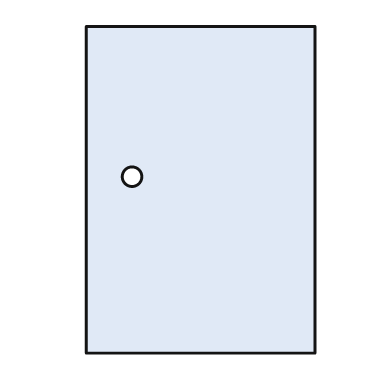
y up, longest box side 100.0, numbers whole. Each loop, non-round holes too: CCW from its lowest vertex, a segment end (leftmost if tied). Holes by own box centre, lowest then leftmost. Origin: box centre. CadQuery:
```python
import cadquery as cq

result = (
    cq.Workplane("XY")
    .moveTo(-35.0, -50.0)
    .lineTo(35.0, -50.0)
    .lineTo(35.0, 50.0)
    .lineTo(-35.0, 50.0)
    .close()
    .moveTo(-21.0, 4.0)
    .circle(3.0)
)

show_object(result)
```